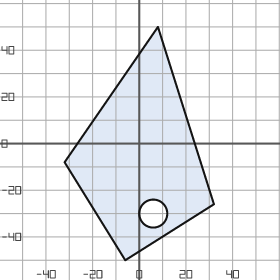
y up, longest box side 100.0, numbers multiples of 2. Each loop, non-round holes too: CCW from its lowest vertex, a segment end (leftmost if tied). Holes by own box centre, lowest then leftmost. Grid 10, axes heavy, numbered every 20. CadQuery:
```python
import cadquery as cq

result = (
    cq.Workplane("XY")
    .moveTo(-6.0, -50.0)
    .lineTo(32.0, -26.0)
    .lineTo(8.0, 50.0)
    .lineTo(-32.0, -8.0)
    .close()
    .moveTo(6.0, -30.0)
    .circle(6.0)
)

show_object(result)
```